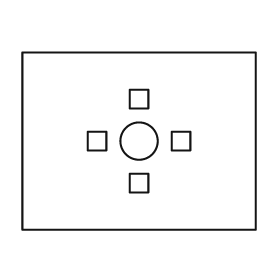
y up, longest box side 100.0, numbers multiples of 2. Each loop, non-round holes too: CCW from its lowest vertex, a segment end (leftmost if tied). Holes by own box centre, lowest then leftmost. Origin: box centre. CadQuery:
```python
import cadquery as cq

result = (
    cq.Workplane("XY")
    .moveTo(-50.0, -38.0)
    .lineTo(50.0, -38.0)
    .lineTo(50.0, 38.0)
    .lineTo(-50.0, 38.0)
    .close()
    .moveTo(-4.0, -22.0)
    .lineTo(4.0, -22.0)
    .lineTo(4.0, -14.0)
    .lineTo(-4.0, -14.0)
    .close()
    .moveTo(-22.0, -4.0)
    .lineTo(-14.0, -4.0)
    .lineTo(-14.0, 4.0)
    .lineTo(-22.0, 4.0)
    .close()
    .moveTo(0.0, 0.0)
    .circle(8.0)
    .moveTo(14.0, -4.0)
    .lineTo(22.0, -4.0)
    .lineTo(22.0, 4.0)
    .lineTo(14.0, 4.0)
    .close()
    .moveTo(-4.0, 14.0)
    .lineTo(4.0, 14.0)
    .lineTo(4.0, 22.0)
    .lineTo(-4.0, 22.0)
    .close()
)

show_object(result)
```